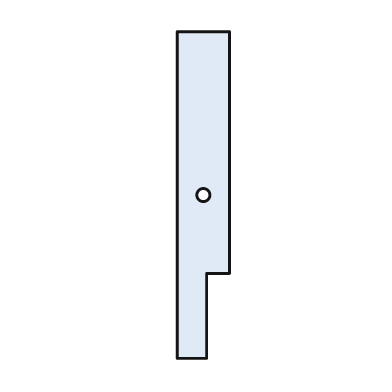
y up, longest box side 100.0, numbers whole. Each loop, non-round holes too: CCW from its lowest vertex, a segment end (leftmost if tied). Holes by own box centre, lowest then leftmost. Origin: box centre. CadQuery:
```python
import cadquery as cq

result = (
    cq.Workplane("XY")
    .moveTo(-8.0, -50.0)
    .lineTo(1.0, -50.0)
    .lineTo(1.0, -24.0)
    .lineTo(8.0, -24.0)
    .lineTo(8.0, 50.0)
    .lineTo(-8.0, 50.0)
    .close()
    .moveTo(0.0, 0.0)
    .circle(2.0)
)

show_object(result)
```